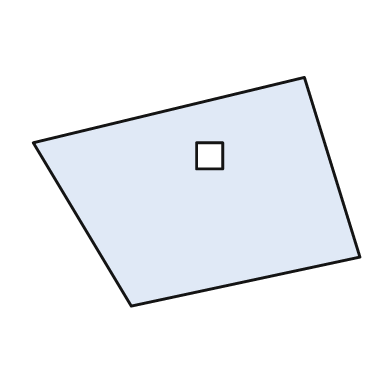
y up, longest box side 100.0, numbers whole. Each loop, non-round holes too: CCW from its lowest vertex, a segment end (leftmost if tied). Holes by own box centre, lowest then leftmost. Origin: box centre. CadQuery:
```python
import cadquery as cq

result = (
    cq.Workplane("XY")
    .moveTo(-20.0, -35.0)
    .lineTo(50.0, -20.0)
    .lineTo(33.0, 35.0)
    .lineTo(-50.0, 15.0)
    .close()
    .moveTo(0.0, 7.0)
    .lineTo(8.0, 7.0)
    .lineTo(8.0, 15.0)
    .lineTo(0.0, 15.0)
    .close()
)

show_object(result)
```